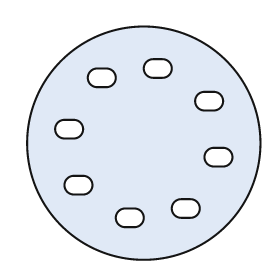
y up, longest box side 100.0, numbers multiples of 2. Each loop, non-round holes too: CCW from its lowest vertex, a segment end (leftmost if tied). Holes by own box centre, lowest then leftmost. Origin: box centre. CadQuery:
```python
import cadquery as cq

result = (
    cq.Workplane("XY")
    .moveTo(0.0, 0.0)
    .circle(50.0)
    .moveTo(-8.0, -36.0)
    .lineTo(-4.0, -36.0)
    .threePointArc((0.0, -32.0), (-4.0, -28.0))
    .lineTo(-8.0, -28.0)
    .threePointArc((-12.0, -32.0), (-8.0, -36.0))
    .close()
    .moveTo(16.0, -32.0)
    .lineTo(20.0, -32.0)
    .threePointArc((24.0, -28.0), (20.0, -24.0))
    .lineTo(16.0, -24.0)
    .threePointArc((12.0, -28.0), (16.0, -32.0))
    .close()
    .moveTo(-30.0, -22.0)
    .lineTo(-26.0, -22.0)
    .threePointArc((-22.0, -18.0), (-26.0, -14.0))
    .lineTo(-30.0, -14.0)
    .threePointArc((-34.0, -18.0), (-30.0, -22.0))
    .close()
    .moveTo(30.0, -10.0)
    .lineTo(34.0, -10.0)
    .threePointArc((38.0, -6.0), (34.0, -2.0))
    .lineTo(30.0, -2.0)
    .threePointArc((26.0, -6.0), (30.0, -10.0))
    .close()
    .moveTo(-34.0, 2.0)
    .lineTo(-30.0, 2.0)
    .threePointArc((-26.0, 6.0), (-30.0, 10.0))
    .lineTo(-34.0, 10.0)
    .threePointArc((-38.0, 6.0), (-34.0, 2.0))
    .close()
    .moveTo(26.0, 14.0)
    .lineTo(30.0, 14.0)
    .threePointArc((34.0, 18.0), (30.0, 22.0))
    .lineTo(26.0, 22.0)
    .threePointArc((22.0, 18.0), (26.0, 14.0))
    .close()
    .moveTo(-20.0, 24.0)
    .lineTo(-16.0, 24.0)
    .threePointArc((-12.0, 28.0), (-16.0, 32.0))
    .lineTo(-20.0, 32.0)
    .threePointArc((-24.0, 28.0), (-20.0, 24.0))
    .close()
    .moveTo(4.0, 28.0)
    .lineTo(8.0, 28.0)
    .threePointArc((12.0, 32.0), (8.0, 36.0))
    .lineTo(4.0, 36.0)
    .threePointArc((0.0, 32.0), (4.0, 28.0))
    .close()
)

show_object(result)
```